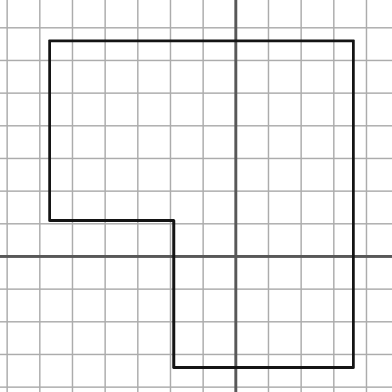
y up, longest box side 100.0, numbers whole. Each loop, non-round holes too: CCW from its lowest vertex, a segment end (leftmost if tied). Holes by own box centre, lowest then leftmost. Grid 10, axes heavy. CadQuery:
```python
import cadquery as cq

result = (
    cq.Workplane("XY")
    .moveTo(-19.0, -34.0)
    .lineTo(36.0, -34.0)
    .lineTo(36.0, 66.0)
    .lineTo(-57.0, 66.0)
    .lineTo(-57.0, 11.0)
    .lineTo(-19.0, 11.0)
    .close()
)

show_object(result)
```